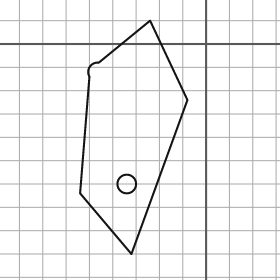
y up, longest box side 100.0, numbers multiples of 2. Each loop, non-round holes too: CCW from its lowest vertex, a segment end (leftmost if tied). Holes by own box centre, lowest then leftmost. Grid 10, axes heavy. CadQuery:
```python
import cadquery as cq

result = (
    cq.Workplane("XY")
    .moveTo(-32.0, -90.0)
    .lineTo(-8.0, -24.0)
    .lineTo(-24.0, 10.0)
    .lineTo(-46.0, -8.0)
    .threePointArc((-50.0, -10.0), (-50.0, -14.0))
    .lineTo(-54.0, -64.0)
    .close()
    .moveTo(-34.0, -60.0)
    .circle(4.0)
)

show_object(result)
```